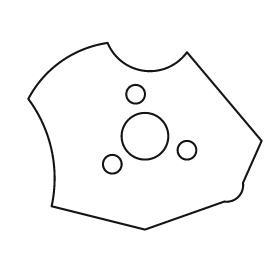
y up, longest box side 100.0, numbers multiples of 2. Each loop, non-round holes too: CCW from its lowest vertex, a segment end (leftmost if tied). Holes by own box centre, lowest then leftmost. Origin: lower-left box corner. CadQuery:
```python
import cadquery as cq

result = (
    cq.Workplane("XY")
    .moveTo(50.0, 0.0)
    .lineTo(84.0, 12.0)
    .threePointArc((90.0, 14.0), (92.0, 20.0))
    .lineTo(100.0, 38.0)
    .lineTo(68.0, 76.0)
    .threePointArc((50.0, 68.0), (34.0, 80.0))
    .threePointArc((14.0, 72.0), (0.0, 56.0))
    .threePointArc((10.0, 34.0), (10.0, 10.0))
    .close()
    .moveTo(36.0, 28.0)
    .circle(4.0)
    .moveTo(68.0, 34.0)
    .circle(4.0)
    .moveTo(50.0, 40.0)
    .circle(10.0)
    .moveTo(46.0, 58.0)
    .circle(4.0)
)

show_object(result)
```